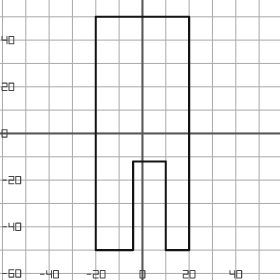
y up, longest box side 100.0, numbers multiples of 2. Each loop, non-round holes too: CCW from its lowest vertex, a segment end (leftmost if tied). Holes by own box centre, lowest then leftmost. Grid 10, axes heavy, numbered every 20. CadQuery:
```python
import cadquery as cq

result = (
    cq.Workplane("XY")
    .moveTo(-20.0, -50.0)
    .lineTo(-4.0, -50.0)
    .lineTo(-4.0, -12.0)
    .lineTo(10.0, -12.0)
    .lineTo(10.0, -50.0)
    .lineTo(20.0, -50.0)
    .lineTo(20.0, 50.0)
    .lineTo(-20.0, 50.0)
    .close()
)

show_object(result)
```